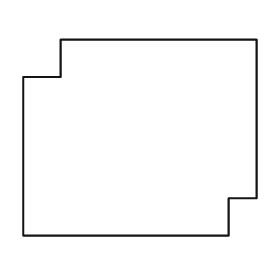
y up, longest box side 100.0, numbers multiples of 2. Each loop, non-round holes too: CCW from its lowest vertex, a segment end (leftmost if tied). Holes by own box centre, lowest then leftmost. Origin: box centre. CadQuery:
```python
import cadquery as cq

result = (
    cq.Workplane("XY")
    .moveTo(-50.0, -42.0)
    .lineTo(38.0, -42.0)
    .lineTo(38.0, -26.0)
    .lineTo(50.0, -26.0)
    .lineTo(50.0, 42.0)
    .lineTo(-34.0, 42.0)
    .lineTo(-34.0, 26.0)
    .lineTo(-50.0, 26.0)
    .close()
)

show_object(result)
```